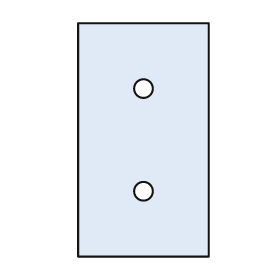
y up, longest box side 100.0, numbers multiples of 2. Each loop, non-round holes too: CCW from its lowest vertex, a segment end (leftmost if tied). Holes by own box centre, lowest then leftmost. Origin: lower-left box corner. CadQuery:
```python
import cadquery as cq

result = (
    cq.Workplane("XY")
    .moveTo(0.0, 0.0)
    .lineTo(56.0, 0.0)
    .lineTo(56.0, 100.0)
    .lineTo(0.0, 100.0)
    .close()
    .moveTo(28.0, 28.0)
    .circle(4.0)
    .moveTo(28.0, 72.0)
    .circle(4.0)
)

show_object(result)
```